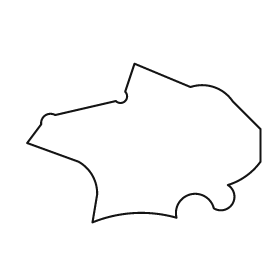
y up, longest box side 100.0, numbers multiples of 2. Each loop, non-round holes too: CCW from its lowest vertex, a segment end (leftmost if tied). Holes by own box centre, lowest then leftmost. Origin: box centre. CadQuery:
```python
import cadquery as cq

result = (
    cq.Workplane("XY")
    .moveTo(-22.0, -34.0)
    .threePointArc((-4.0, -30.0), (14.0, -32.0))
    .threePointArc((20.0, -22.0), (30.0, -28.0))
    .threePointArc((38.0, -26.0), (36.0, -18.0))
    .threePointArc((44.0, -14.0), (50.0, -8.0))
    .lineTo(50.0, 6.0)
    .lineTo(38.0, 18.0)
    .threePointArc((30.0, 24.0), (20.0, 24.0))
    .lineTo(-4.0, 34.0)
    .lineTo(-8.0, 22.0)
    .threePointArc((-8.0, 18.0), (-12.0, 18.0))
    .lineTo(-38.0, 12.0)
    .threePointArc((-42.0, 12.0), (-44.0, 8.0))
    .lineTo(-50.0, 0.0)
    .lineTo(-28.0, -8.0)
    .threePointArc((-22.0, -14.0), (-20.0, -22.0))
    .close()
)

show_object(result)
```